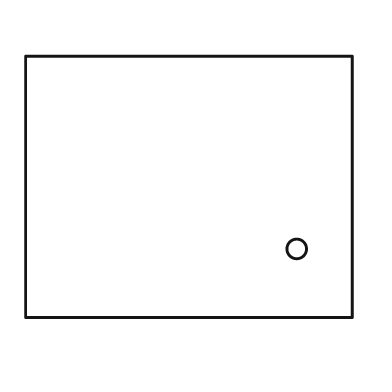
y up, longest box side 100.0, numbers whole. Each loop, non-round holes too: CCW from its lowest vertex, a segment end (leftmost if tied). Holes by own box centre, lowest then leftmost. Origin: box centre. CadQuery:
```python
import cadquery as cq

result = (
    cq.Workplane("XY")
    .moveTo(-50.0, -40.0)
    .lineTo(50.0, -40.0)
    .lineTo(50.0, 40.0)
    .lineTo(-50.0, 40.0)
    .close()
    .moveTo(33.0, -19.0)
    .circle(3.0)
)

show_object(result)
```